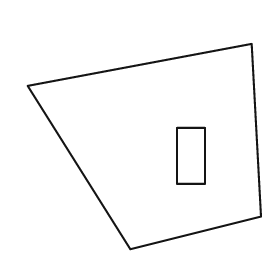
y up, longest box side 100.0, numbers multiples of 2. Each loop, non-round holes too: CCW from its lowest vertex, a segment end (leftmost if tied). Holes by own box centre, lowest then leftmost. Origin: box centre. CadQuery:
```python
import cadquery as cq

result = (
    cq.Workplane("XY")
    .moveTo(-6.0, -44.0)
    .lineTo(50.0, -30.0)
    .lineTo(46.0, 44.0)
    .lineTo(-50.0, 26.0)
    .close()
    .moveTo(14.0, -16.0)
    .lineTo(26.0, -16.0)
    .lineTo(26.0, 8.0)
    .lineTo(14.0, 8.0)
    .close()
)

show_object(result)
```